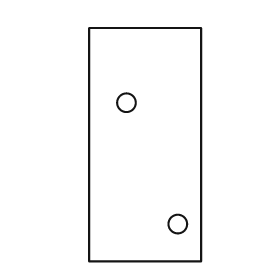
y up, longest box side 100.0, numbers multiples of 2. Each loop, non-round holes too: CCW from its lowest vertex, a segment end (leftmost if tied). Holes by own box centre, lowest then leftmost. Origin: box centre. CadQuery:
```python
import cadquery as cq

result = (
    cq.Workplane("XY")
    .moveTo(-24.0, -50.0)
    .lineTo(24.0, -50.0)
    .lineTo(24.0, 50.0)
    .lineTo(-24.0, 50.0)
    .close()
    .moveTo(14.0, -34.0)
    .circle(4.0)
    .moveTo(-8.0, 18.0)
    .circle(4.0)
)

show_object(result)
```